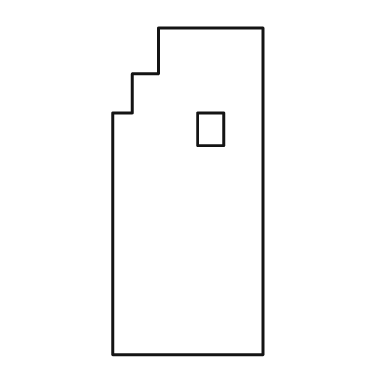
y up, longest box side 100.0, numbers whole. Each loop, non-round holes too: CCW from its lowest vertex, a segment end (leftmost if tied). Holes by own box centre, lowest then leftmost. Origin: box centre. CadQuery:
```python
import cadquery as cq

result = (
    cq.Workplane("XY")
    .moveTo(-23.0, -50.0)
    .lineTo(23.0, -50.0)
    .lineTo(23.0, 50.0)
    .lineTo(-9.0, 50.0)
    .lineTo(-9.0, 36.0)
    .lineTo(-17.0, 36.0)
    .lineTo(-17.0, 24.0)
    .lineTo(-23.0, 24.0)
    .close()
    .moveTo(3.0, 14.0)
    .lineTo(11.0, 14.0)
    .lineTo(11.0, 24.0)
    .lineTo(3.0, 24.0)
    .close()
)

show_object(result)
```